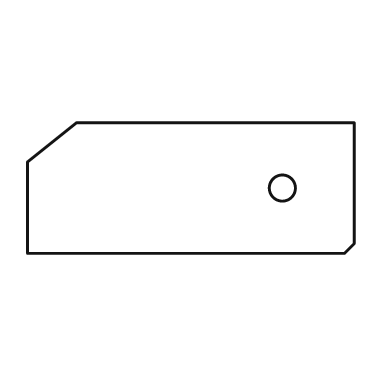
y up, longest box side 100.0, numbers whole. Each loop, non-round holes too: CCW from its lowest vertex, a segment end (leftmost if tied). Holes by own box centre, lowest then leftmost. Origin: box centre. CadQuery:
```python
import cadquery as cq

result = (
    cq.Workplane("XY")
    .moveTo(-50.0, -20.0)
    .lineTo(47.0, -20.0)
    .lineTo(50.0, -17.0)
    .lineTo(50.0, 20.0)
    .lineTo(-35.0, 20.0)
    .lineTo(-50.0, 8.0)
    .close()
    .moveTo(28.0, 0.0)
    .circle(4.0)
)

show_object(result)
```